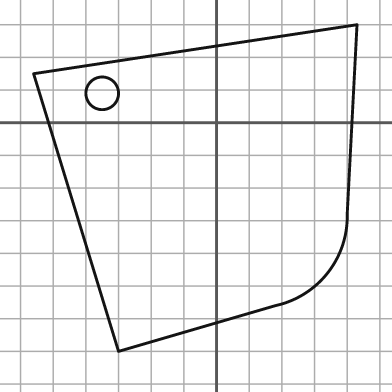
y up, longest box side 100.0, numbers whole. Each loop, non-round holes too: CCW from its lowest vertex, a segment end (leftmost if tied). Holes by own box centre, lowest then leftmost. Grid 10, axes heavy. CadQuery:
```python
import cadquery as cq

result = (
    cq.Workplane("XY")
    .moveTo(-30.0, -70.0)
    .lineTo(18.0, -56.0)
    .threePointArc((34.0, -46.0), (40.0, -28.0))
    .lineTo(43.0, 30.0)
    .lineTo(-56.0, 15.0)
    .close()
    .moveTo(-35.0, 9.0)
    .circle(5.0)
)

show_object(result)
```